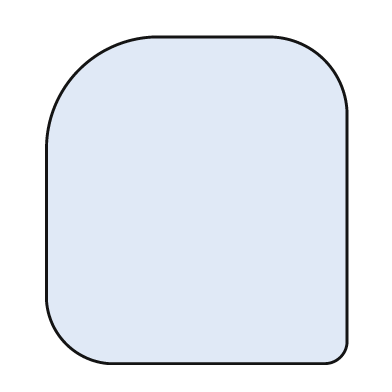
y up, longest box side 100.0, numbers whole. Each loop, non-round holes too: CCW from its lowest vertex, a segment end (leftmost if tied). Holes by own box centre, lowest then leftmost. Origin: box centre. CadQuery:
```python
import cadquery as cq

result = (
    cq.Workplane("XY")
    .moveTo(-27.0, -50.0)
    .lineTo(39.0, -50.0)
    .threePointArc((44.0, -48.0), (46.0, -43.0))
    .lineTo(46.0, 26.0)
    .threePointArc((39.0, 43.0), (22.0, 50.0))
    .lineTo(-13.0, 50.0)
    .threePointArc((-36.0, 40.0), (-46.0, 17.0))
    .lineTo(-46.0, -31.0)
    .threePointArc((-40.0, -44.0), (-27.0, -50.0))
    .close()
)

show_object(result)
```